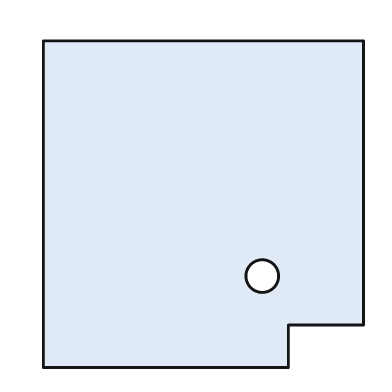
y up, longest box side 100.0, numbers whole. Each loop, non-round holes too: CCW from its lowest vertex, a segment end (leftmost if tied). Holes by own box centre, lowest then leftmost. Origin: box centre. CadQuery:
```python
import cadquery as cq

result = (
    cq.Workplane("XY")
    .moveTo(-49.0, -50.0)
    .lineTo(26.0, -50.0)
    .lineTo(26.0, -37.0)
    .lineTo(49.0, -37.0)
    .lineTo(49.0, 50.0)
    .lineTo(-49.0, 50.0)
    .close()
    .moveTo(18.0, -22.0)
    .circle(5.0)
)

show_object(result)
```